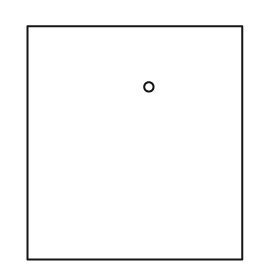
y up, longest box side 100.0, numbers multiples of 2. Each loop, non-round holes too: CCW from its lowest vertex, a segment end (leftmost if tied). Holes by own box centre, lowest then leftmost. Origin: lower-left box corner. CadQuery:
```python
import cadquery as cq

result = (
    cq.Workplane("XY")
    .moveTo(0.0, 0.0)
    .lineTo(92.0, 0.0)
    .lineTo(92.0, 100.0)
    .lineTo(0.0, 100.0)
    .close()
    .moveTo(52.0, 74.0)
    .circle(2.0)
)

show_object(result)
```